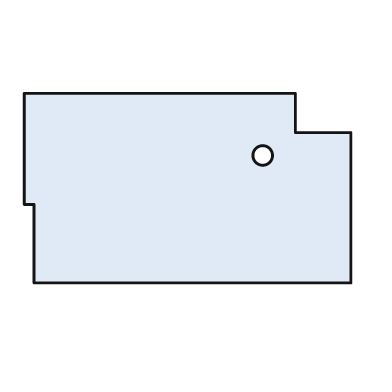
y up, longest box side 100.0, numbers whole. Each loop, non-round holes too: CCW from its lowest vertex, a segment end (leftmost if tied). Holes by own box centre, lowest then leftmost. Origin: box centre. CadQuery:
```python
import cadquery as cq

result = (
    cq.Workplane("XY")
    .moveTo(-47.0, -29.0)
    .lineTo(50.0, -29.0)
    .lineTo(50.0, 17.0)
    .lineTo(33.0, 17.0)
    .lineTo(33.0, 29.0)
    .lineTo(-50.0, 29.0)
    .lineTo(-50.0, -5.0)
    .lineTo(-47.0, -5.0)
    .close()
    .moveTo(23.0, 10.0)
    .circle(3.0)
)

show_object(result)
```